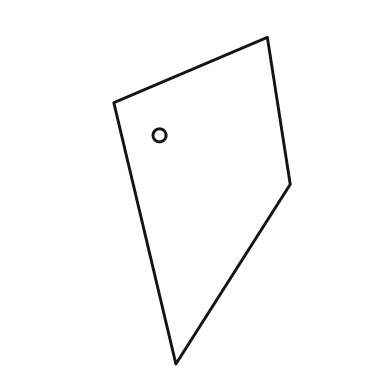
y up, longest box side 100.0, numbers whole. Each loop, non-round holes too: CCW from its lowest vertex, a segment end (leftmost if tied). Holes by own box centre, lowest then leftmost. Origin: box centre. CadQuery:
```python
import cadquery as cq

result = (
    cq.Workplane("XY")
    .moveTo(-8.0, -50.0)
    .lineTo(27.0, 5.0)
    .lineTo(20.0, 50.0)
    .lineTo(-27.0, 30.0)
    .close()
    .moveTo(-13.0, 20.0)
    .circle(2.0)
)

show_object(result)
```